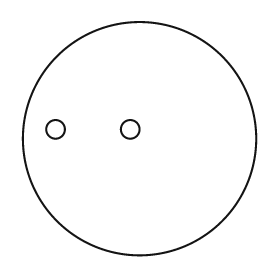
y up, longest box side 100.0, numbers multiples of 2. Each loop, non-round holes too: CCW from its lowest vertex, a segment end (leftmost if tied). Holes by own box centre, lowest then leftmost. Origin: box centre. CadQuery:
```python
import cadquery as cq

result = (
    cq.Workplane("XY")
    .moveTo(0.0, 0.0)
    .circle(50.0)
    .moveTo(-36.0, 4.0)
    .circle(4.0)
    .moveTo(-4.0, 4.0)
    .circle(4.0)
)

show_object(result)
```